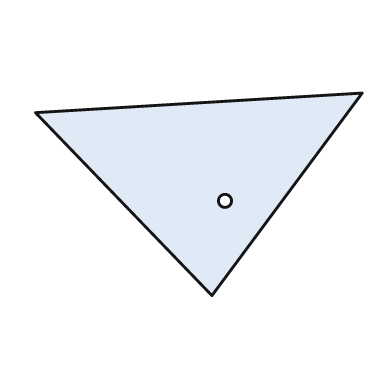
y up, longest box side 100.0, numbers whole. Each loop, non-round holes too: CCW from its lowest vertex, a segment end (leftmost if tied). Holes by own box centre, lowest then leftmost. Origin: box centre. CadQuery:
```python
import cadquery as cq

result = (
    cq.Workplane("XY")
    .moveTo(4.0, -31.0)
    .lineTo(50.0, 31.0)
    .lineTo(-50.0, 25.0)
    .close()
    .moveTo(8.0, -2.0)
    .circle(2.0)
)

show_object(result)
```